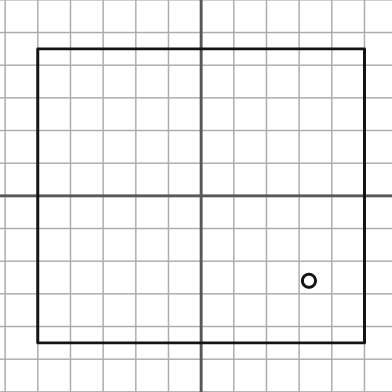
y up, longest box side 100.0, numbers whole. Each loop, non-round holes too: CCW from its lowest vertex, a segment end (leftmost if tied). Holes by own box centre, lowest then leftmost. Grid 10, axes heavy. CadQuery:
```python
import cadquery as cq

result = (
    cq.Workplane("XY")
    .moveTo(-50.0, -45.0)
    .lineTo(50.0, -45.0)
    .lineTo(50.0, 45.0)
    .lineTo(-50.0, 45.0)
    .close()
    .moveTo(33.0, -26.0)
    .circle(2.0)
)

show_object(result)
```